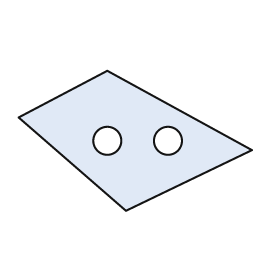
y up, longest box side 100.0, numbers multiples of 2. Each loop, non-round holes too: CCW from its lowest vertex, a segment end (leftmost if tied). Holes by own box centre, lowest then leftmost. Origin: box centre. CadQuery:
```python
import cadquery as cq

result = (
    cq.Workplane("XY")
    .moveTo(-4.0, -30.0)
    .lineTo(50.0, -4.0)
    .lineTo(-12.0, 30.0)
    .lineTo(-50.0, 10.0)
    .close()
    .moveTo(-12.0, 0.0)
    .circle(6.0)
    .moveTo(14.0, 0.0)
    .circle(6.0)
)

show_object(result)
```